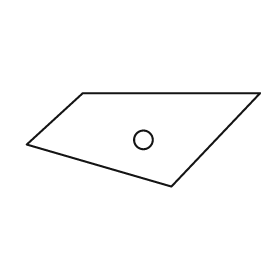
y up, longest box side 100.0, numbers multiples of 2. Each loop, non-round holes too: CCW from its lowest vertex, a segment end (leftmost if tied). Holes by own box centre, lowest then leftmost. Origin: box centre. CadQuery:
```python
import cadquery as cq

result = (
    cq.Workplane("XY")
    .moveTo(12.0, -20.0)
    .lineTo(50.0, 20.0)
    .lineTo(-26.0, 20.0)
    .lineTo(-50.0, -2.0)
    .close()
    .moveTo(0.0, 0.0)
    .circle(4.0)
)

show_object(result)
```